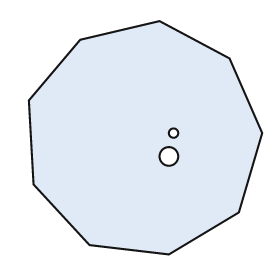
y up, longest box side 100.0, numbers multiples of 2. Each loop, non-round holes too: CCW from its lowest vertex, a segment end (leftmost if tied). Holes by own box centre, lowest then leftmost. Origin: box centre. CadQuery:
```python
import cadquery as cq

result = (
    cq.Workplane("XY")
    .moveTo(10.0, -50.0)
    .lineTo(40.0, -32.0)
    .lineTo(50.0, 2.0)
    .lineTo(36.0, 34.0)
    .lineTo(6.0, 50.0)
    .lineTo(-28.0, 42.0)
    .lineTo(-50.0, 16.0)
    .lineTo(-48.0, -20.0)
    .lineTo(-24.0, -46.0)
    .close()
    .moveTo(10.0, -8.0)
    .circle(4.0)
    .moveTo(12.0, 2.0)
    .circle(2.0)
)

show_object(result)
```